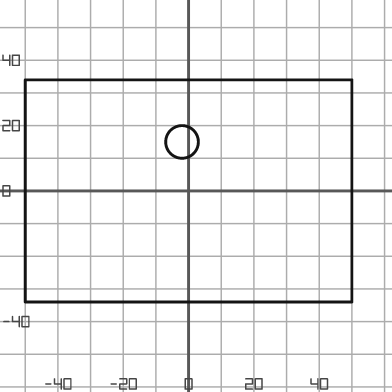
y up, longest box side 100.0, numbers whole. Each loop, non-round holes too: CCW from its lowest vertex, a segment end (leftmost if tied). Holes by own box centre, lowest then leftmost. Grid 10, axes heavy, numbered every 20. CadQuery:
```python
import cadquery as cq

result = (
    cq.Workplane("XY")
    .moveTo(-50.0, -34.0)
    .lineTo(50.0, -34.0)
    .lineTo(50.0, 34.0)
    .lineTo(-50.0, 34.0)
    .close()
    .moveTo(-2.0, 15.0)
    .circle(5.0)
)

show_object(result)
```